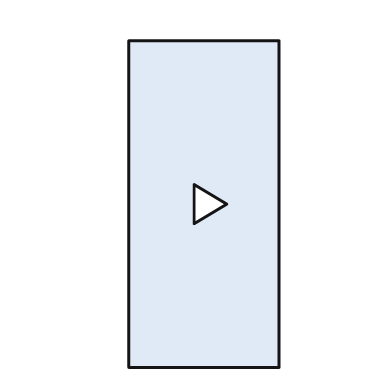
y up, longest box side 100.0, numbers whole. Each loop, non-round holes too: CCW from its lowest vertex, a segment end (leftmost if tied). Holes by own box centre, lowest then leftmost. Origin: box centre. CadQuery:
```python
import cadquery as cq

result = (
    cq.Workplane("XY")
    .moveTo(-23.0, -50.0)
    .lineTo(23.0, -50.0)
    .lineTo(23.0, 50.0)
    .lineTo(-23.0, 50.0)
    .close()
    .moveTo(-3.0, -6.0)
    .lineTo(7.0, 0.0)
    .lineTo(-3.0, 6.0)
    .close()
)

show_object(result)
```